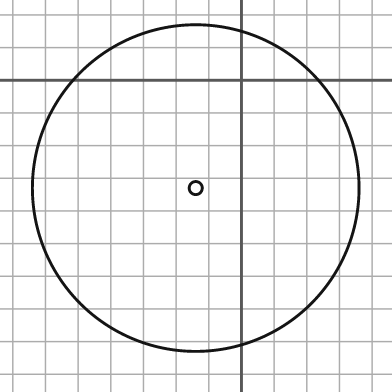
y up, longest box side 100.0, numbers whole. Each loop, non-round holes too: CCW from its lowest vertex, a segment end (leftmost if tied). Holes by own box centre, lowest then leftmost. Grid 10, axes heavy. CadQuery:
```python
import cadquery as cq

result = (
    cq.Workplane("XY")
    .moveTo(-14.0, -33.0)
    .circle(50.0)
    .moveTo(-14.0, -33.0)
    .circle(2.0)
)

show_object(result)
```